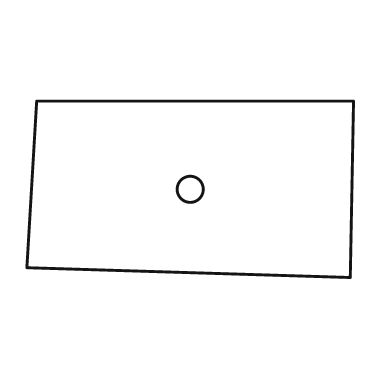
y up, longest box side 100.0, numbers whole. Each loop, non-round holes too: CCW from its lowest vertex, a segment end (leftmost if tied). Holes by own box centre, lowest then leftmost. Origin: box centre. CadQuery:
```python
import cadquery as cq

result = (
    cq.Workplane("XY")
    .moveTo(49.0, -27.0)
    .lineTo(50.0, 27.0)
    .lineTo(-47.0, 27.0)
    .lineTo(-50.0, -24.0)
    .close()
    .moveTo(0.0, 0.0)
    .circle(4.0)
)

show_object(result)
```